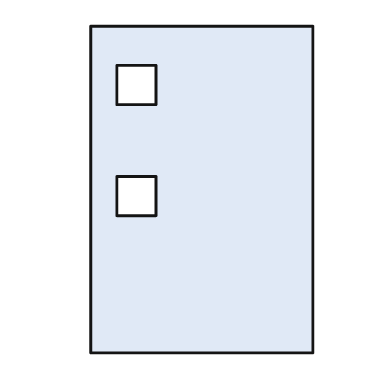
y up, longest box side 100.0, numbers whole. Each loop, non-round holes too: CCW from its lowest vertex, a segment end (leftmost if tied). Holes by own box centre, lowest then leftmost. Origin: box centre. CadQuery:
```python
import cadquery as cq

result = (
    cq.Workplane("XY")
    .moveTo(-34.0, -50.0)
    .lineTo(34.0, -50.0)
    .lineTo(34.0, 50.0)
    .lineTo(-34.0, 50.0)
    .close()
    .moveTo(-26.0, -8.0)
    .lineTo(-14.0, -8.0)
    .lineTo(-14.0, 4.0)
    .lineTo(-26.0, 4.0)
    .close()
    .moveTo(-26.0, 26.0)
    .lineTo(-14.0, 26.0)
    .lineTo(-14.0, 38.0)
    .lineTo(-26.0, 38.0)
    .close()
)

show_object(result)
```